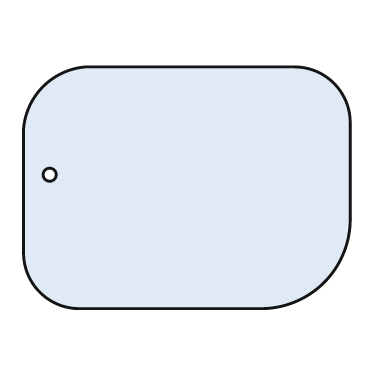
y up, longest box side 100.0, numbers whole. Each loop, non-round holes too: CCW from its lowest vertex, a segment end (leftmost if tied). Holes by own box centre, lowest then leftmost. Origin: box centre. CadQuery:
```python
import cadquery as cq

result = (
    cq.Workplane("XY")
    .moveTo(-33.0, -37.0)
    .lineTo(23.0, -37.0)
    .threePointArc((42.0, -29.0), (50.0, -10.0))
    .lineTo(50.0, 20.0)
    .threePointArc((45.0, 32.0), (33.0, 37.0))
    .lineTo(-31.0, 37.0)
    .threePointArc((-44.0, 31.0), (-50.0, 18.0))
    .lineTo(-50.0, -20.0)
    .threePointArc((-45.0, -32.0), (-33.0, -37.0))
    .close()
    .moveTo(-42.0, 4.0)
    .circle(2.0)
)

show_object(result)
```